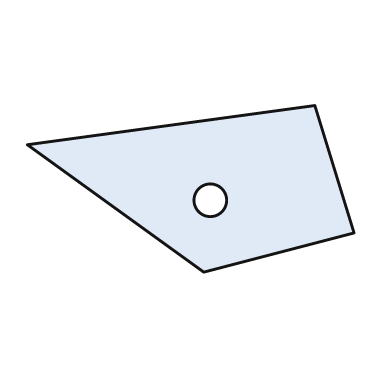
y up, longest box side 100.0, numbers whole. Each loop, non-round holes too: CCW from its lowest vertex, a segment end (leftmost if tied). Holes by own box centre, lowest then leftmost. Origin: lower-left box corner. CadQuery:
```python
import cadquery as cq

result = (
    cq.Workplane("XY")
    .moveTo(54.0, 0.0)
    .lineTo(100.0, 12.0)
    .lineTo(88.0, 51.0)
    .lineTo(0.0, 39.0)
    .close()
    .moveTo(56.0, 22.0)
    .circle(5.0)
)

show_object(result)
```